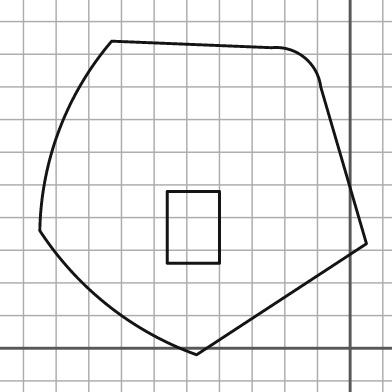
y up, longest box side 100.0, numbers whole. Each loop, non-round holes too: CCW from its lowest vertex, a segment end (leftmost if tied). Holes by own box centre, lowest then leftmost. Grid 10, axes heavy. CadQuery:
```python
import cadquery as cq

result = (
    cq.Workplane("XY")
    .moveTo(-47.0, -2.0)
    .lineTo(5.0, 32.0)
    .lineTo(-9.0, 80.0)
    .threePointArc((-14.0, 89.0), (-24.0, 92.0))
    .lineTo(-73.0, 94.0)
    .threePointArc((-89.0, 67.0), (-95.0, 36.0))
    .threePointArc((-74.0, 13.0), (-47.0, -2.0))
    .close()
    .moveTo(-56.0, 26.0)
    .lineTo(-40.0, 26.0)
    .lineTo(-40.0, 48.0)
    .lineTo(-56.0, 48.0)
    .close()
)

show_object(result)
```